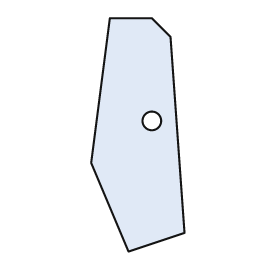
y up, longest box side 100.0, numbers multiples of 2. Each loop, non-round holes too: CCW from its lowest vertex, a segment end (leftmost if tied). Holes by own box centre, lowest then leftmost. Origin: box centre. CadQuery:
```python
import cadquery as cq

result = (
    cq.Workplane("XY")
    .moveTo(-4.0, -50.0)
    .lineTo(20.0, -42.0)
    .lineTo(14.0, 42.0)
    .lineTo(6.0, 50.0)
    .lineTo(-12.0, 50.0)
    .lineTo(-20.0, -12.0)
    .close()
    .moveTo(6.0, 6.0)
    .circle(4.0)
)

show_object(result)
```